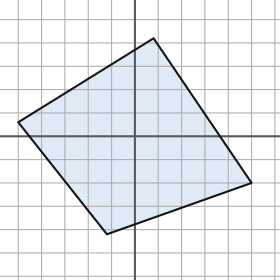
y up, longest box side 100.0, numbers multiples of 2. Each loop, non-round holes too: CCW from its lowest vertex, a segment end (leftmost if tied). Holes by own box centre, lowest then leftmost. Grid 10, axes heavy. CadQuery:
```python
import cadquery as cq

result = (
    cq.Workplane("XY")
    .moveTo(-12.0, -42.0)
    .lineTo(50.0, -20.0)
    .lineTo(8.0, 42.0)
    .lineTo(-50.0, 6.0)
    .close()
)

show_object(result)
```